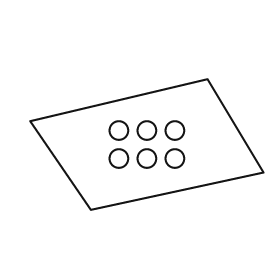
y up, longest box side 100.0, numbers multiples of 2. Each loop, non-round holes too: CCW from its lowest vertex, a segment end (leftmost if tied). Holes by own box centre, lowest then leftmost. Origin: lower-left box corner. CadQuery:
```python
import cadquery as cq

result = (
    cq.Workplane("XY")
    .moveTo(26.0, 0.0)
    .lineTo(100.0, 16.0)
    .lineTo(76.0, 56.0)
    .lineTo(0.0, 38.0)
    .close()
    .moveTo(38.0, 22.0)
    .circle(4.0)
    .moveTo(50.0, 22.0)
    .circle(4.0)
    .moveTo(62.0, 22.0)
    .circle(4.0)
    .moveTo(38.0, 34.0)
    .circle(4.0)
    .moveTo(50.0, 34.0)
    .circle(4.0)
    .moveTo(62.0, 34.0)
    .circle(4.0)
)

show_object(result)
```